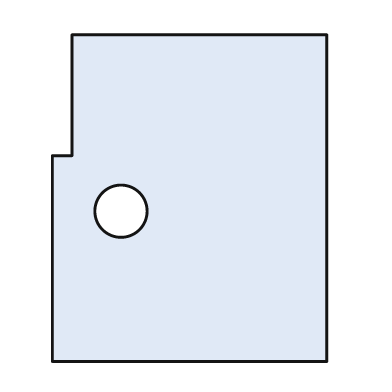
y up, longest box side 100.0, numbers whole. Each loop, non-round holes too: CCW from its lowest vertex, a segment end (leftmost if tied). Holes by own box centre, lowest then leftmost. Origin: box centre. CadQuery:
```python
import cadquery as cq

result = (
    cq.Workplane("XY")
    .moveTo(-42.0, -50.0)
    .lineTo(42.0, -50.0)
    .lineTo(42.0, 50.0)
    .lineTo(-36.0, 50.0)
    .lineTo(-36.0, 13.0)
    .lineTo(-42.0, 13.0)
    .close()
    .moveTo(-21.0, -4.0)
    .circle(8.0)
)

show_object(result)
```